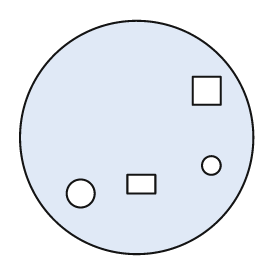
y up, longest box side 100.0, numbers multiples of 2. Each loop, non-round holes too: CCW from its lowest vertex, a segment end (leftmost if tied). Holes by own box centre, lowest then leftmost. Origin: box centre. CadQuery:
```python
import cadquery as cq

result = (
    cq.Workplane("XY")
    .moveTo(0.0, 0.0)
    .circle(50.0)
    .moveTo(-24.0, -24.0)
    .circle(6.0)
    .moveTo(-4.0, -24.0)
    .lineTo(8.0, -24.0)
    .lineTo(8.0, -16.0)
    .lineTo(-4.0, -16.0)
    .close()
    .moveTo(32.0, -12.0)
    .circle(4.0)
    .moveTo(24.0, 14.0)
    .lineTo(36.0, 14.0)
    .lineTo(36.0, 26.0)
    .lineTo(24.0, 26.0)
    .close()
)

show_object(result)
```